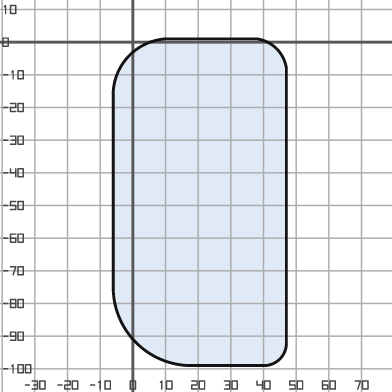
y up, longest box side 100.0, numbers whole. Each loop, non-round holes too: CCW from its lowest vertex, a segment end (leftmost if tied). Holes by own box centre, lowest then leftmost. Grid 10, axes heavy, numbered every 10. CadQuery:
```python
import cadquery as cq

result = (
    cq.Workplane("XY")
    .moveTo(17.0, -99.0)
    .lineTo(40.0, -99.0)
    .threePointArc((45.0, -97.0), (47.0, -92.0))
    .lineTo(47.0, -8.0)
    .threePointArc((44.0, -2.0), (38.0, 1.0))
    .lineTo(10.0, 1.0)
    .threePointArc((-1.0, -4.0), (-6.0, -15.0))
    .lineTo(-6.0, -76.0)
    .threePointArc((1.0, -92.0), (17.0, -99.0))
    .close()
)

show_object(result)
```